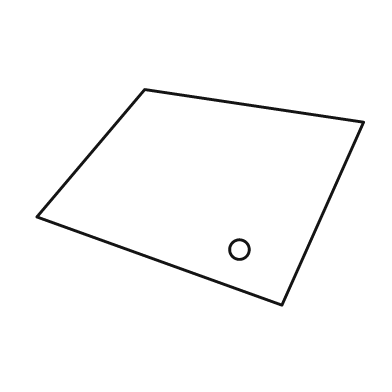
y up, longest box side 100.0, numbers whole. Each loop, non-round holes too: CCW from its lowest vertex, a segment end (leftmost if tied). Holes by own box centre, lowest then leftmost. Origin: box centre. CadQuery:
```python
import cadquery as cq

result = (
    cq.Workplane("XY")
    .moveTo(25.0, -33.0)
    .lineTo(50.0, 23.0)
    .lineTo(-17.0, 33.0)
    .lineTo(-50.0, -6.0)
    .close()
    .moveTo(12.0, -16.0)
    .circle(3.0)
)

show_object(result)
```